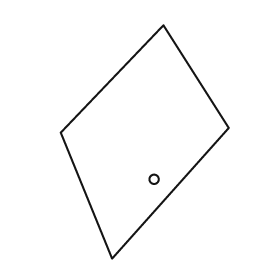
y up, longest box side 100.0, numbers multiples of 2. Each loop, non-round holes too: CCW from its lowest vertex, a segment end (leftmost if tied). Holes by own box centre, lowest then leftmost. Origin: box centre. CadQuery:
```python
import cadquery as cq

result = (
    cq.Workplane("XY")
    .moveTo(-14.0, -50.0)
    .lineTo(36.0, 6.0)
    .lineTo(8.0, 50.0)
    .lineTo(-36.0, 4.0)
    .close()
    .moveTo(4.0, -16.0)
    .circle(2.0)
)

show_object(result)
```